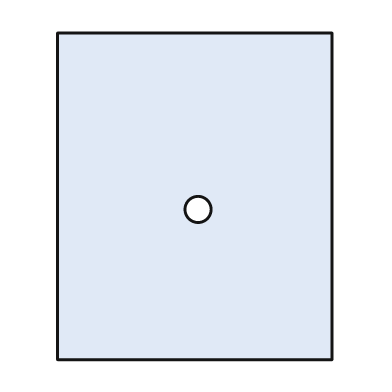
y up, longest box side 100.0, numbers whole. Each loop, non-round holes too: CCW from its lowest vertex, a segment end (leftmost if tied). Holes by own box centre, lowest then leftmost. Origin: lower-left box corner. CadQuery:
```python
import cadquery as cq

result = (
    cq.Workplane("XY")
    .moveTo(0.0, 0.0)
    .lineTo(84.0, 0.0)
    .lineTo(84.0, 100.0)
    .lineTo(0.0, 100.0)
    .close()
    .moveTo(43.0, 46.0)
    .circle(4.0)
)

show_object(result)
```